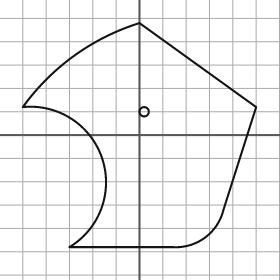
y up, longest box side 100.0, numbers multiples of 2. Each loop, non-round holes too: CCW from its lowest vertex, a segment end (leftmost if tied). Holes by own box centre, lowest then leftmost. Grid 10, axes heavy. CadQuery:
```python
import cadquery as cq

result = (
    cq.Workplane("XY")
    .moveTo(-30.0, -48.0)
    .lineTo(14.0, -48.0)
    .threePointArc((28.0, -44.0), (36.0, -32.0))
    .lineTo(50.0, 12.0)
    .lineTo(0.0, 48.0)
    .threePointArc((-28.0, 34.0), (-50.0, 12.0))
    .threePointArc((-16.0, -10.0), (-30.0, -48.0))
    .close()
    .moveTo(2.0, 10.0)
    .circle(2.0)
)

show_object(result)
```